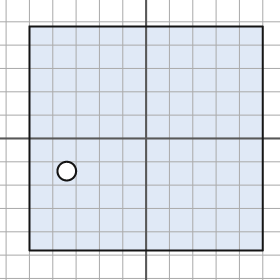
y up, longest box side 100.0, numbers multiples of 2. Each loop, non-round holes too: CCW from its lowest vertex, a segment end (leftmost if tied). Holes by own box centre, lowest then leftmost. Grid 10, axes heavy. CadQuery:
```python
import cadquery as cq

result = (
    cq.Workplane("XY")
    .moveTo(-50.0, -48.0)
    .lineTo(50.0, -48.0)
    .lineTo(50.0, 48.0)
    .lineTo(-50.0, 48.0)
    .close()
    .moveTo(-34.0, -14.0)
    .circle(4.0)
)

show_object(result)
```